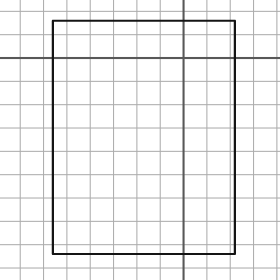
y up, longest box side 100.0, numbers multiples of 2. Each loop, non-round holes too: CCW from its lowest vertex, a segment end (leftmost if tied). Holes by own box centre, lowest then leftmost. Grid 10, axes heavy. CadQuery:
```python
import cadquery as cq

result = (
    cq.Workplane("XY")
    .moveTo(-56.0, -84.0)
    .lineTo(22.0, -84.0)
    .lineTo(22.0, 16.0)
    .lineTo(-56.0, 16.0)
    .close()
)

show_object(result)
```